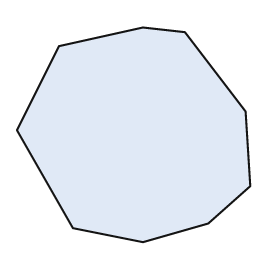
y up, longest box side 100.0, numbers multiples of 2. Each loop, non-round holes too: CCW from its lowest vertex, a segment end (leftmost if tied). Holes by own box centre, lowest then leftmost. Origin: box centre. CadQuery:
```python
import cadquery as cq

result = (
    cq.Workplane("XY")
    .moveTo(4.0, -46.0)
    .lineTo(32.0, -38.0)
    .lineTo(50.0, -22.0)
    .lineTo(48.0, 10.0)
    .lineTo(22.0, 44.0)
    .lineTo(4.0, 46.0)
    .lineTo(-32.0, 38.0)
    .lineTo(-50.0, 2.0)
    .lineTo(-26.0, -40.0)
    .close()
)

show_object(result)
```